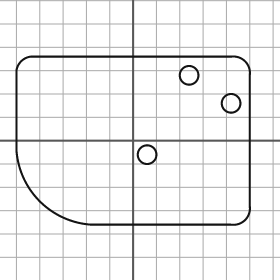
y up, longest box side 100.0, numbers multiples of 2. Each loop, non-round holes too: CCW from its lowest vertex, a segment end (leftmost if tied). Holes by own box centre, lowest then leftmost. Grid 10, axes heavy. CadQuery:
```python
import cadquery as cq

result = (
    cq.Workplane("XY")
    .moveTo(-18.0, -36.0)
    .lineTo(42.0, -36.0)
    .threePointArc((48.0, -34.0), (50.0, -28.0))
    .lineTo(50.0, 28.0)
    .threePointArc((48.0, 34.0), (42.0, 36.0))
    .lineTo(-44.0, 36.0)
    .threePointArc((-48.0, 34.0), (-50.0, 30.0))
    .lineTo(-50.0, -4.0)
    .threePointArc((-40.0, -26.0), (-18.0, -36.0))
    .close()
    .moveTo(6.0, -6.0)
    .circle(4.0)
    .moveTo(42.0, 16.0)
    .circle(4.0)
    .moveTo(24.0, 28.0)
    .circle(4.0)
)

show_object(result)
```